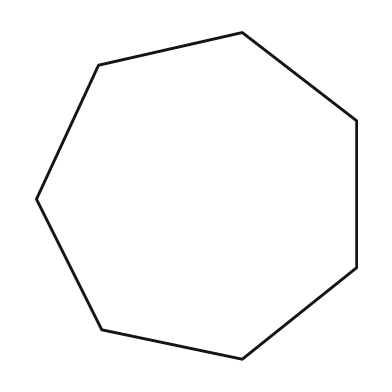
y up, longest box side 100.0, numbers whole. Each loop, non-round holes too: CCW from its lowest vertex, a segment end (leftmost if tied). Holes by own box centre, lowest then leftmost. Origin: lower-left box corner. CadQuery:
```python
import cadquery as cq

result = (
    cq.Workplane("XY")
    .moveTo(63.0, 0.0)
    .lineTo(98.0, 28.0)
    .lineTo(98.0, 73.0)
    .lineTo(63.0, 100.0)
    .lineTo(19.0, 90.0)
    .lineTo(0.0, 49.0)
    .lineTo(20.0, 9.0)
    .close()
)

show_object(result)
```